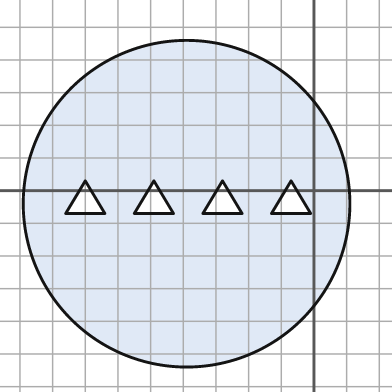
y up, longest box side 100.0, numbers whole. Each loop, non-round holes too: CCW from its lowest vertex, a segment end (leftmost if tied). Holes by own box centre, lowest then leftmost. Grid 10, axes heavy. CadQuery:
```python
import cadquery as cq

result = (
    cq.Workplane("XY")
    .moveTo(-39.0, -4.0)
    .circle(50.0)
    .moveTo(-76.0, -7.0)
    .lineTo(-64.0, -7.0)
    .lineTo(-70.0, 3.0)
    .close()
    .moveTo(-55.0, -7.0)
    .lineTo(-43.0, -7.0)
    .lineTo(-49.0, 3.0)
    .close()
    .moveTo(-34.0, -7.0)
    .lineTo(-22.0, -7.0)
    .lineTo(-28.0, 3.0)
    .close()
    .moveTo(-13.0, -7.0)
    .lineTo(-1.0, -7.0)
    .lineTo(-7.0, 3.0)
    .close()
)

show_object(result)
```